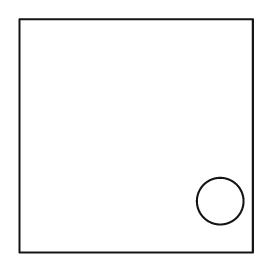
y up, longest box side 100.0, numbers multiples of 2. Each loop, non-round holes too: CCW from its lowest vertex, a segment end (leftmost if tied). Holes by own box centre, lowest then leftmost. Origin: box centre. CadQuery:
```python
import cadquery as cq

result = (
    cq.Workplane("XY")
    .moveTo(-50.0, -50.0)
    .lineTo(50.0, -50.0)
    .lineTo(50.0, 50.0)
    .lineTo(-50.0, 50.0)
    .close()
    .moveTo(36.0, -28.0)
    .circle(10.0)
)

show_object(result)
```